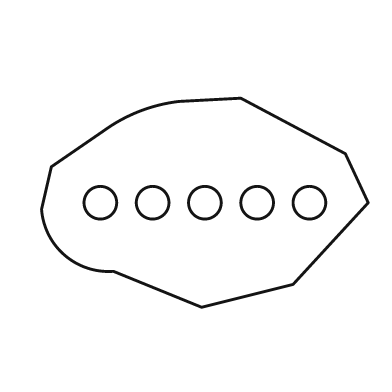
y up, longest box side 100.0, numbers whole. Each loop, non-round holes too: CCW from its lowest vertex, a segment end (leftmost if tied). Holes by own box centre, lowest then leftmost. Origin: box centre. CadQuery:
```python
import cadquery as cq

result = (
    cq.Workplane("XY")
    .moveTo(-1.0, -32.0)
    .lineTo(27.0, -25.0)
    .lineTo(50.0, 0.0)
    .lineTo(43.0, 15.0)
    .lineTo(11.0, 32.0)
    .lineTo(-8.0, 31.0)
    .threePointArc((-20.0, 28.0), (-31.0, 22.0))
    .lineTo(-47.0, 11.0)
    .lineTo(-50.0, -2.0)
    .threePointArc((-43.0, -16.0), (-28.0, -21.0))
    .close()
    .moveTo(-32.0, 0.0)
    .circle(5.0)
    .moveTo(-16.0, 0.0)
    .circle(5.0)
    .moveTo(0.0, 0.0)
    .circle(5.0)
    .moveTo(16.0, 0.0)
    .circle(5.0)
    .moveTo(32.0, 0.0)
    .circle(5.0)
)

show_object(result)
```